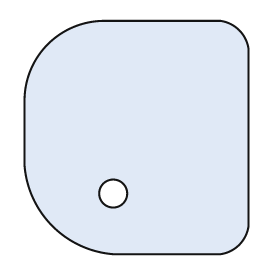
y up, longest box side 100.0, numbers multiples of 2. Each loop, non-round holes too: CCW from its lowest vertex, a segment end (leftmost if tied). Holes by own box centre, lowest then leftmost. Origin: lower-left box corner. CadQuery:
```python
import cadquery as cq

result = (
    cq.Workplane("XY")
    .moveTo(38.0, 0.0)
    .lineTo(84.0, 0.0)
    .threePointArc((92.0, 4.0), (96.0, 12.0))
    .lineTo(96.0, 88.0)
    .threePointArc((92.0, 96.0), (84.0, 100.0))
    .lineTo(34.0, 100.0)
    .threePointArc((10.0, 90.0), (0.0, 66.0))
    .lineTo(0.0, 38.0)
    .threePointArc((12.0, 12.0), (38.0, 0.0))
    .close()
    .moveTo(38.0, 26.0)
    .circle(6.0)
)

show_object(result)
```